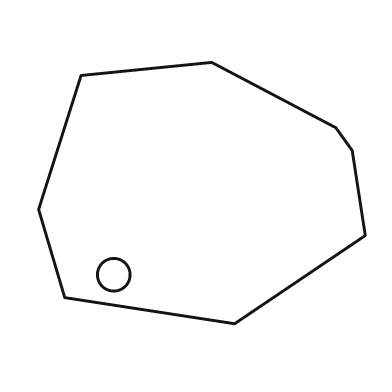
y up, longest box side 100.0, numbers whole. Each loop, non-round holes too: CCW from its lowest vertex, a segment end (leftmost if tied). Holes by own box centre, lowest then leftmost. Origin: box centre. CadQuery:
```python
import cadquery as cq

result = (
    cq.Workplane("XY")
    .moveTo(10.0, -40.0)
    .lineTo(50.0, -13.0)
    .lineTo(46.0, 13.0)
    .lineTo(41.0, 20.0)
    .lineTo(3.0, 40.0)
    .lineTo(-37.0, 36.0)
    .lineTo(-50.0, -5.0)
    .lineTo(-42.0, -32.0)
    .close()
    .moveTo(-27.0, -25.0)
    .circle(5.0)
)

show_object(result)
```